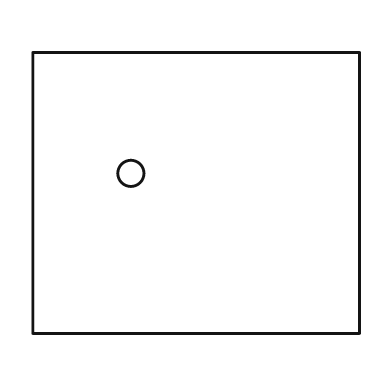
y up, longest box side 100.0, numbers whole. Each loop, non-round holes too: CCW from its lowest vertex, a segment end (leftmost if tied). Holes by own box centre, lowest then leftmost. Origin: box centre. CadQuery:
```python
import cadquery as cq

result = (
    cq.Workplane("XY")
    .moveTo(-50.0, -43.0)
    .lineTo(50.0, -43.0)
    .lineTo(50.0, 43.0)
    .lineTo(-50.0, 43.0)
    .close()
    .moveTo(-20.0, 6.0)
    .circle(4.0)
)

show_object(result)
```